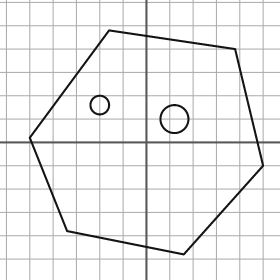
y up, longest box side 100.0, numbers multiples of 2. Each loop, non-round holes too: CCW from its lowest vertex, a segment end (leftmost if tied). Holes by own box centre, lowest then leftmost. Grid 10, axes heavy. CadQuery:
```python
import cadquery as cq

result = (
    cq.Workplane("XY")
    .moveTo(16.0, -48.0)
    .lineTo(50.0, -10.0)
    .lineTo(38.0, 40.0)
    .lineTo(-16.0, 48.0)
    .lineTo(-50.0, 2.0)
    .lineTo(-34.0, -38.0)
    .close()
    .moveTo(12.0, 10.0)
    .circle(6.0)
    .moveTo(-20.0, 16.0)
    .circle(4.0)
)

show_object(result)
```